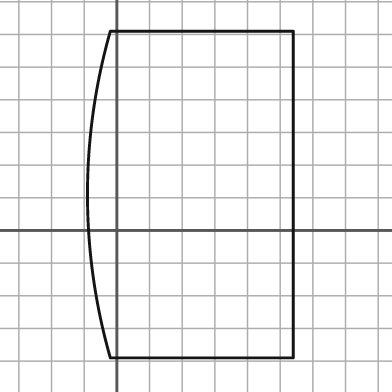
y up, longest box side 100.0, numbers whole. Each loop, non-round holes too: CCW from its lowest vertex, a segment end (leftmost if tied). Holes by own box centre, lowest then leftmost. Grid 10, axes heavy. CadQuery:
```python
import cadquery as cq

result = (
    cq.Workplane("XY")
    .moveTo(-2.0, -39.0)
    .lineTo(54.0, -39.0)
    .lineTo(54.0, 61.0)
    .lineTo(-2.0, 61.0)
    .threePointArc((-9.0, 11.0), (-2.0, -39.0))
    .close()
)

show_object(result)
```